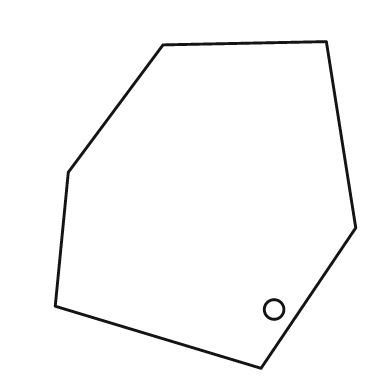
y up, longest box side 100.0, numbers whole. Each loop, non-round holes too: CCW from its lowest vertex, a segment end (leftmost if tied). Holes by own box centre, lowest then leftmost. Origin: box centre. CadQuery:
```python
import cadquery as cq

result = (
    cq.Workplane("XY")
    .moveTo(17.0, -50.0)
    .lineTo(46.0, -7.0)
    .lineTo(37.0, 50.0)
    .lineTo(-13.0, 49.0)
    .lineTo(-42.0, 10.0)
    .lineTo(-46.0, -31.0)
    .close()
    .moveTo(21.0, -32.0)
    .circle(3.0)
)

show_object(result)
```